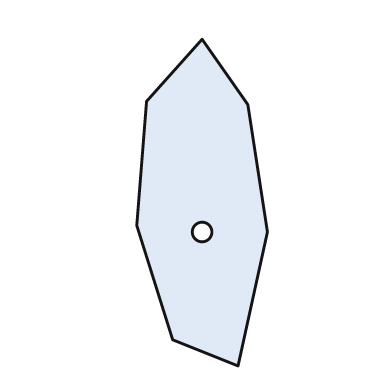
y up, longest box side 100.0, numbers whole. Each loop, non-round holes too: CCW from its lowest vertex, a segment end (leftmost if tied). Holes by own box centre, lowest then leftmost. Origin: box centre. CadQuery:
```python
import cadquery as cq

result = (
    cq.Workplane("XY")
    .moveTo(11.0, -50.0)
    .lineTo(20.0, -9.0)
    .lineTo(14.0, 30.0)
    .lineTo(0.0, 50.0)
    .lineTo(-17.0, 31.0)
    .lineTo(-20.0, -7.0)
    .lineTo(-9.0, -42.0)
    .close()
    .moveTo(0.0, -9.0)
    .circle(3.0)
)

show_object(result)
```